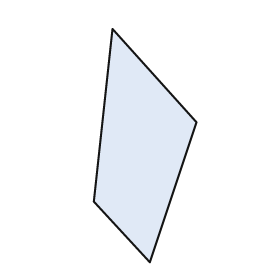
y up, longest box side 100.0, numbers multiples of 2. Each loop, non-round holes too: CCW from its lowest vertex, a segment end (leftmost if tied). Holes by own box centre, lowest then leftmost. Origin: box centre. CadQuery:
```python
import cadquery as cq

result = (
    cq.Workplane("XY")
    .moveTo(2.0, -50.0)
    .lineTo(22.0, 10.0)
    .lineTo(-14.0, 50.0)
    .lineTo(-22.0, -24.0)
    .close()
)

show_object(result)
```